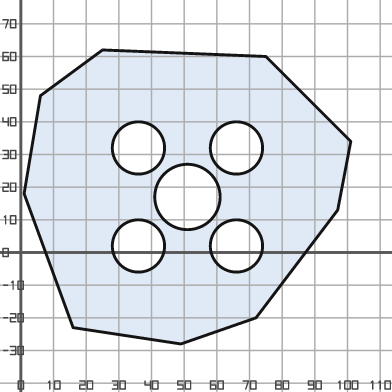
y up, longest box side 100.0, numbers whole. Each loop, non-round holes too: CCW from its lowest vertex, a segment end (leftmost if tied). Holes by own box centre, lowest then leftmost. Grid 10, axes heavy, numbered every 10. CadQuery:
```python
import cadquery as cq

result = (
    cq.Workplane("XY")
    .moveTo(49.0, -28.0)
    .lineTo(72.0, -20.0)
    .lineTo(97.0, 13.0)
    .lineTo(101.0, 34.0)
    .lineTo(75.0, 60.0)
    .lineTo(25.0, 62.0)
    .lineTo(6.0, 48.0)
    .lineTo(1.0, 18.0)
    .lineTo(16.0, -23.0)
    .close()
    .moveTo(36.0, 2.0)
    .circle(8.0)
    .moveTo(66.0, 2.0)
    .circle(8.0)
    .moveTo(51.0, 17.0)
    .circle(10.0)
    .moveTo(36.0, 32.0)
    .circle(8.0)
    .moveTo(66.0, 32.0)
    .circle(8.0)
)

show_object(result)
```